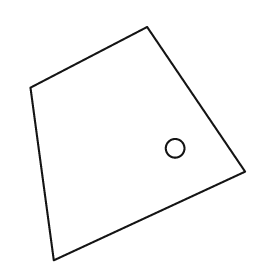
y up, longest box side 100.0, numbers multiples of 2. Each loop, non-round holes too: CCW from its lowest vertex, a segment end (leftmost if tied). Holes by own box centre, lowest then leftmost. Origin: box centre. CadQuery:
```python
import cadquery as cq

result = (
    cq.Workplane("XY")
    .moveTo(-36.0, -50.0)
    .lineTo(46.0, -12.0)
    .lineTo(4.0, 50.0)
    .lineTo(-46.0, 24.0)
    .close()
    .moveTo(16.0, -2.0)
    .circle(4.0)
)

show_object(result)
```